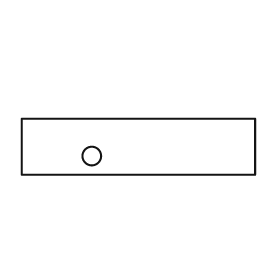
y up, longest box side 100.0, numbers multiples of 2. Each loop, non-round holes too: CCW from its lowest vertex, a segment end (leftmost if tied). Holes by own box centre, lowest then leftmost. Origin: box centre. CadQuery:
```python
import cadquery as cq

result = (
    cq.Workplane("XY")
    .moveTo(-50.0, -12.0)
    .lineTo(50.0, -12.0)
    .lineTo(50.0, 12.0)
    .lineTo(-50.0, 12.0)
    .close()
    .moveTo(-20.0, -4.0)
    .circle(4.0)
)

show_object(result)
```